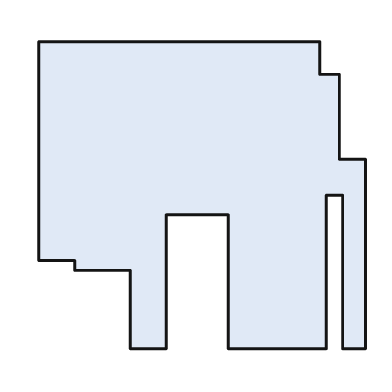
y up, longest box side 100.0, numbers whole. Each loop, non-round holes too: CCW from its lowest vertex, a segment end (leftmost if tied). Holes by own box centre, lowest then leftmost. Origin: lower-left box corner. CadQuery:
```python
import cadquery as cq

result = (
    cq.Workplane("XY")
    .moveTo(28.0, 0.0)
    .lineTo(39.0, 0.0)
    .lineTo(39.0, 41.0)
    .lineTo(58.0, 41.0)
    .lineTo(58.0, 0.0)
    .lineTo(88.0, 0.0)
    .lineTo(88.0, 47.0)
    .lineTo(93.0, 47.0)
    .lineTo(93.0, 0.0)
    .lineTo(100.0, 0.0)
    .lineTo(100.0, 58.0)
    .lineTo(92.0, 58.0)
    .lineTo(92.0, 84.0)
    .lineTo(86.0, 84.0)
    .lineTo(86.0, 94.0)
    .lineTo(0.0, 94.0)
    .lineTo(0.0, 27.0)
    .lineTo(11.0, 27.0)
    .lineTo(11.0, 24.0)
    .lineTo(28.0, 24.0)
    .close()
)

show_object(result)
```